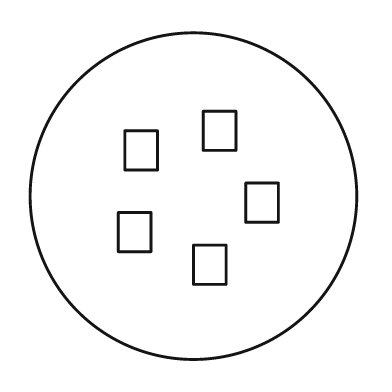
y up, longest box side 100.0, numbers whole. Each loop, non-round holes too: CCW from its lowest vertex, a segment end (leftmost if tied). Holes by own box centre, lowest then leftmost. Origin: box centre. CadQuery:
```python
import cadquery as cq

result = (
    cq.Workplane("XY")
    .moveTo(0.0, 0.0)
    .circle(50.0)
    .moveTo(0.0, -27.0)
    .lineTo(10.0, -27.0)
    .lineTo(10.0, -15.0)
    .lineTo(0.0, -15.0)
    .close()
    .moveTo(-23.0, -17.0)
    .lineTo(-13.0, -17.0)
    .lineTo(-13.0, -5.0)
    .lineTo(-23.0, -5.0)
    .close()
    .moveTo(16.0, -8.0)
    .lineTo(26.0, -8.0)
    .lineTo(26.0, 4.0)
    .lineTo(16.0, 4.0)
    .close()
    .moveTo(-21.0, 8.0)
    .lineTo(-11.0, 8.0)
    .lineTo(-11.0, 20.0)
    .lineTo(-21.0, 20.0)
    .close()
    .moveTo(3.0, 14.0)
    .lineTo(13.0, 14.0)
    .lineTo(13.0, 26.0)
    .lineTo(3.0, 26.0)
    .close()
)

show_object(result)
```